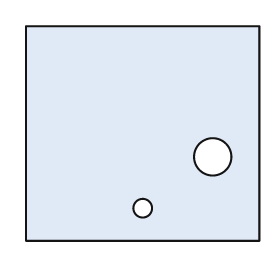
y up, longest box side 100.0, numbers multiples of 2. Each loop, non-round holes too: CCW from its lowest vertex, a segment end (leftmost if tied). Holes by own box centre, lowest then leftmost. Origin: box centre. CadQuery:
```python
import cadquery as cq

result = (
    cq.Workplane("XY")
    .moveTo(-50.0, -46.0)
    .lineTo(50.0, -46.0)
    .lineTo(50.0, 46.0)
    .lineTo(-50.0, 46.0)
    .close()
    .moveTo(0.0, -32.0)
    .circle(4.0)
    .moveTo(30.0, -10.0)
    .circle(8.0)
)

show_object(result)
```